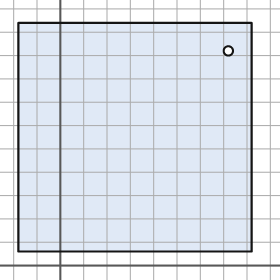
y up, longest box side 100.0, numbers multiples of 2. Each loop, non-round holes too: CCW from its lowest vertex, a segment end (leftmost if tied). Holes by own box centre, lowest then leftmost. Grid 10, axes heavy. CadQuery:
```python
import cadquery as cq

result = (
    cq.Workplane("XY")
    .moveTo(-18.0, 6.0)
    .lineTo(82.0, 6.0)
    .lineTo(82.0, 104.0)
    .lineTo(-18.0, 104.0)
    .close()
    .moveTo(72.0, 92.0)
    .circle(2.0)
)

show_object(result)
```